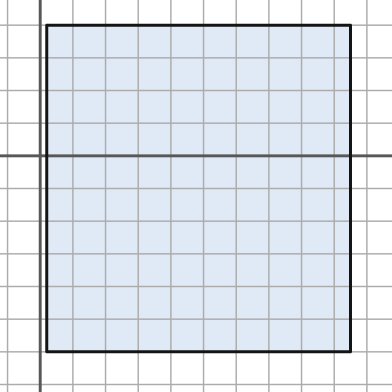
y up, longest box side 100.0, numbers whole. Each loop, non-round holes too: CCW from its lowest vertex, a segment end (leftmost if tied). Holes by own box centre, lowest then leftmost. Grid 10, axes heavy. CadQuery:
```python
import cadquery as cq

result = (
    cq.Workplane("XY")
    .moveTo(2.0, -60.0)
    .lineTo(95.0, -60.0)
    .lineTo(95.0, 40.0)
    .lineTo(2.0, 40.0)
    .close()
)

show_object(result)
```